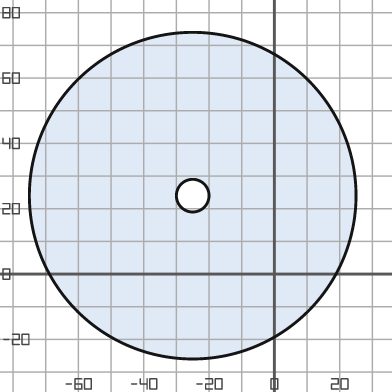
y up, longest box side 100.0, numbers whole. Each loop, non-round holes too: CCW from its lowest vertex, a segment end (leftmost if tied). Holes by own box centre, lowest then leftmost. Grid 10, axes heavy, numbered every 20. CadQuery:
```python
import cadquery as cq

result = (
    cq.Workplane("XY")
    .moveTo(-25.0, 24.0)
    .circle(50.0)
    .moveTo(-25.0, 24.0)
    .circle(5.0)
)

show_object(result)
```